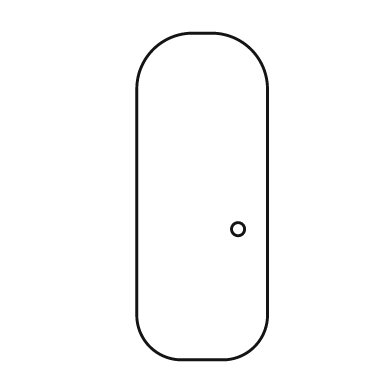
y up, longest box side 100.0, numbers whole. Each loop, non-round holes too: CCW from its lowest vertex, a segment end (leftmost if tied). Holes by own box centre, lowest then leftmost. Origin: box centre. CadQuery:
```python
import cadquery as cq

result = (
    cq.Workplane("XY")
    .moveTo(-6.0, -50.0)
    .lineTo(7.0, -50.0)
    .threePointArc((16.0, -46.0), (20.0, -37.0))
    .lineTo(20.0, 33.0)
    .threePointArc((15.0, 45.0), (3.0, 50.0))
    .lineTo(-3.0, 50.0)
    .threePointArc((-15.0, 45.0), (-20.0, 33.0))
    .lineTo(-20.0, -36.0)
    .threePointArc((-16.0, -46.0), (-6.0, -50.0))
    .close()
    .moveTo(11.0, -10.0)
    .circle(2.0)
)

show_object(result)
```